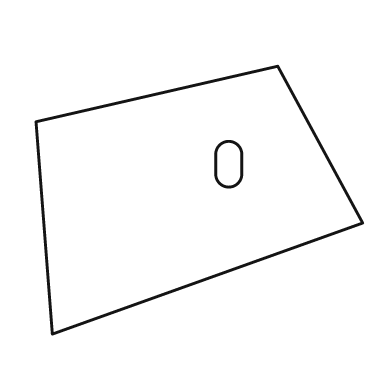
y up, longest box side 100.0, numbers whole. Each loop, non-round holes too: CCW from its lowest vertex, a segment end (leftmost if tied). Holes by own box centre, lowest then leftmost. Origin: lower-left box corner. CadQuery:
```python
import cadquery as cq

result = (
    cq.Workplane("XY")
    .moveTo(5.0, 0.0)
    .lineTo(100.0, 34.0)
    .lineTo(74.0, 82.0)
    .lineTo(0.0, 65.0)
    .close()
    .moveTo(55.0, 49.0)
    .threePointArc((59.0, 45.0), (63.0, 49.0))
    .lineTo(63.0, 55.0)
    .threePointArc((59.0, 59.0), (55.0, 55.0))
    .close()
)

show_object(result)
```